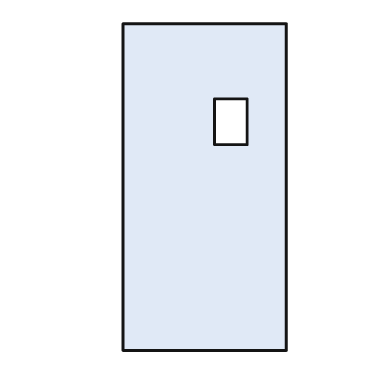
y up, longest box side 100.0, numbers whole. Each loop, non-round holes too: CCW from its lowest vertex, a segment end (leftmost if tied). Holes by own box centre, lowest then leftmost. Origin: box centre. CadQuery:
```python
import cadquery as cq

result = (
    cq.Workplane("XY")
    .moveTo(-25.0, -50.0)
    .lineTo(25.0, -50.0)
    .lineTo(25.0, 50.0)
    .lineTo(-25.0, 50.0)
    .close()
    .moveTo(3.0, 13.0)
    .lineTo(13.0, 13.0)
    .lineTo(13.0, 27.0)
    .lineTo(3.0, 27.0)
    .close()
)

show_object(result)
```